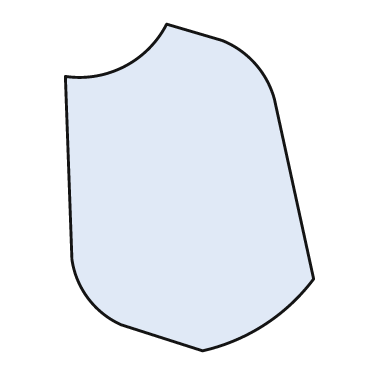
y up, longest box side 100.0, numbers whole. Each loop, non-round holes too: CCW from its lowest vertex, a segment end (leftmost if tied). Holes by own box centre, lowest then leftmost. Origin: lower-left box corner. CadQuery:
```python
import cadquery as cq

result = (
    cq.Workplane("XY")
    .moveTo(42.0, 0.0)
    .threePointArc((61.0, 8.0), (76.0, 22.0))
    .lineTo(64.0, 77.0)
    .threePointArc((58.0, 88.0), (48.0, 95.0))
    .lineTo(31.0, 100.0)
    .threePointArc((18.0, 87.0), (0.0, 84.0))
    .lineTo(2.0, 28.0)
    .threePointArc((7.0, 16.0), (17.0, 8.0))
    .close()
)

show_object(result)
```